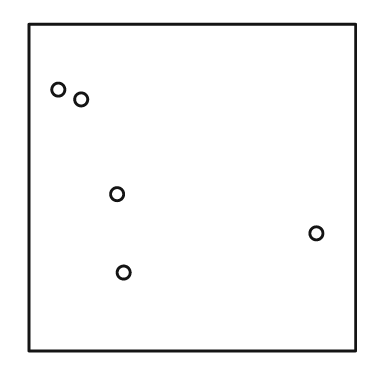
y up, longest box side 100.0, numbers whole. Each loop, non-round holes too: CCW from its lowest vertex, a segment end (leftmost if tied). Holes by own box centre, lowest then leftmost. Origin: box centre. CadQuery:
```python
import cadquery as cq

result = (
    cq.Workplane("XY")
    .moveTo(-50.0, -50.0)
    .lineTo(50.0, -50.0)
    .lineTo(50.0, 50.0)
    .lineTo(-50.0, 50.0)
    .close()
    .moveTo(-21.0, -26.0)
    .circle(2.0)
    .moveTo(38.0, -14.0)
    .circle(2.0)
    .moveTo(-23.0, -2.0)
    .circle(2.0)
    .moveTo(-34.0, 27.0)
    .circle(2.0)
    .moveTo(-41.0, 30.0)
    .circle(2.0)
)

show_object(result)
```